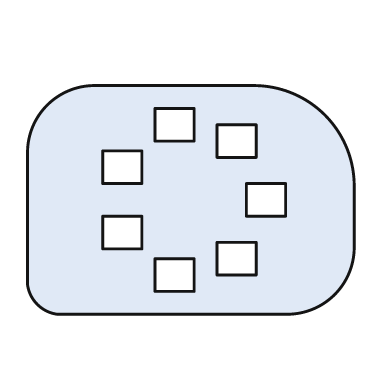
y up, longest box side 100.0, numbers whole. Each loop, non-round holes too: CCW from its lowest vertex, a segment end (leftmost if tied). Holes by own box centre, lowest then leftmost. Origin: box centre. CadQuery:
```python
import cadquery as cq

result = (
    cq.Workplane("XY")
    .moveTo(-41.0, -35.0)
    .lineTo(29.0, -35.0)
    .threePointArc((44.0, -29.0), (50.0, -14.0))
    .lineTo(50.0, 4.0)
    .threePointArc((41.0, 26.0), (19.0, 35.0))
    .lineTo(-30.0, 35.0)
    .threePointArc((-44.0, 29.0), (-50.0, 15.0))
    .lineTo(-50.0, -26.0)
    .threePointArc((-47.0, -32.0), (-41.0, -35.0))
    .close()
    .moveTo(-11.0, -28.0)
    .lineTo(1.0, -28.0)
    .lineTo(1.0, -18.0)
    .lineTo(-11.0, -18.0)
    .close()
    .moveTo(8.0, -23.0)
    .lineTo(20.0, -23.0)
    .lineTo(20.0, -13.0)
    .lineTo(8.0, -13.0)
    .close()
    .moveTo(-27.0, -15.0)
    .lineTo(-15.0, -15.0)
    .lineTo(-15.0, -5.0)
    .lineTo(-27.0, -5.0)
    .close()
    .moveTo(17.0, -5.0)
    .lineTo(29.0, -5.0)
    .lineTo(29.0, 5.0)
    .lineTo(17.0, 5.0)
    .close()
    .moveTo(-27.0, 5.0)
    .lineTo(-15.0, 5.0)
    .lineTo(-15.0, 15.0)
    .lineTo(-27.0, 15.0)
    .close()
    .moveTo(8.0, 13.0)
    .lineTo(20.0, 13.0)
    .lineTo(20.0, 23.0)
    .lineTo(8.0, 23.0)
    .close()
    .moveTo(-11.0, 18.0)
    .lineTo(1.0, 18.0)
    .lineTo(1.0, 28.0)
    .lineTo(-11.0, 28.0)
    .close()
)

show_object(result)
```